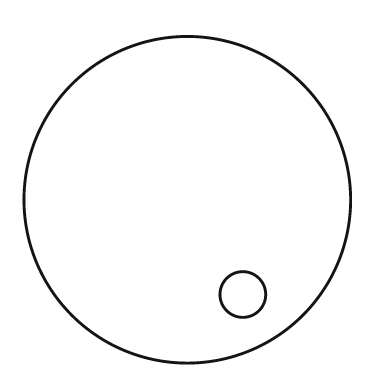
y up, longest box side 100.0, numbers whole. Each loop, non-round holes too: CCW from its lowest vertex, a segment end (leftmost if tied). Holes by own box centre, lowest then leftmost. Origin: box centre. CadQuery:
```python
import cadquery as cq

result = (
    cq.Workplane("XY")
    .moveTo(0.0, 0.0)
    .circle(50.0)
    .moveTo(17.0, -29.0)
    .circle(7.0)
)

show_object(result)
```